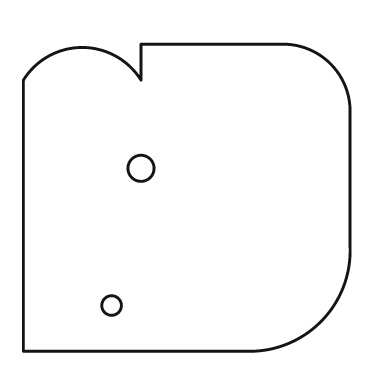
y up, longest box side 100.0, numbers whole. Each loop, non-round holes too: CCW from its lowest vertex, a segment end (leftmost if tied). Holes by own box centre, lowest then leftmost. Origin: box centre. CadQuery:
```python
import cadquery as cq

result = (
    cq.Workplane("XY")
    .moveTo(-50.0, -47.0)
    .lineTo(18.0, -47.0)
    .threePointArc((41.0, -38.0), (50.0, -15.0))
    .lineTo(50.0, 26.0)
    .threePointArc((44.0, 41.0), (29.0, 47.0))
    .lineTo(-14.0, 47.0)
    .lineTo(-14.0, 36.0)
    .threePointArc((-32.0, 46.0), (-50.0, 36.0))
    .close()
    .moveTo(-23.0, -33.0)
    .circle(3.0)
    .moveTo(-14.0, 9.0)
    .circle(4.0)
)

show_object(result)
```